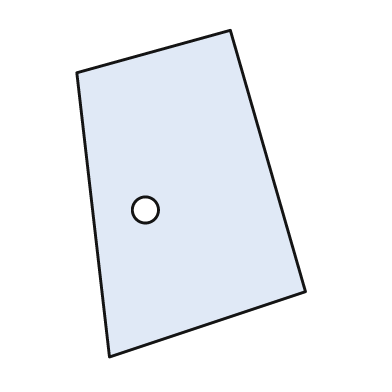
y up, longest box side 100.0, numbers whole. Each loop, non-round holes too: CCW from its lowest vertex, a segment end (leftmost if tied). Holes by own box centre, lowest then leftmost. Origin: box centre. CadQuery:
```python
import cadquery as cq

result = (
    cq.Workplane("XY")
    .moveTo(-25.0, -50.0)
    .lineTo(35.0, -30.0)
    .lineTo(12.0, 50.0)
    .lineTo(-35.0, 37.0)
    .close()
    .moveTo(-14.0, -5.0)
    .circle(4.0)
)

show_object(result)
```